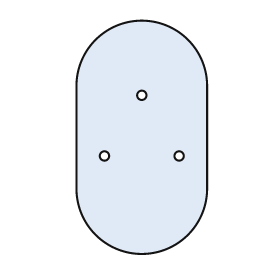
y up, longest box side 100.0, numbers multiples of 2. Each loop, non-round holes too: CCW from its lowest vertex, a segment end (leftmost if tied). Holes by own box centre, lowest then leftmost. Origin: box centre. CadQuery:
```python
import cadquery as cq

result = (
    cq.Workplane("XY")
    .moveTo(-28.0, -22.0)
    .threePointArc((0.0, -50.0), (28.0, -22.0))
    .lineTo(28.0, 22.0)
    .threePointArc((0.0, 50.0), (-28.0, 22.0))
    .close()
    .moveTo(-16.0, -8.0)
    .circle(2.0)
    .moveTo(16.0, -8.0)
    .circle(2.0)
    .moveTo(0.0, 18.0)
    .circle(2.0)
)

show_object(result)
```